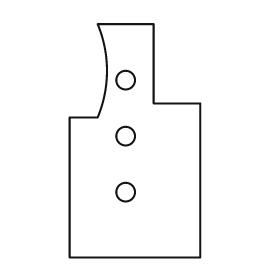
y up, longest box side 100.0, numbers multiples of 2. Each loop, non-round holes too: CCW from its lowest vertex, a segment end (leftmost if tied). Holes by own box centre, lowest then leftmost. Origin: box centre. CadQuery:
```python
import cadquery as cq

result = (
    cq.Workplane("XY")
    .moveTo(-28.0, -50.0)
    .lineTo(28.0, -50.0)
    .lineTo(28.0, 16.0)
    .lineTo(8.0, 16.0)
    .lineTo(8.0, 50.0)
    .lineTo(-16.0, 50.0)
    .threePointArc((-12.0, 30.0), (-16.0, 10.0))
    .lineTo(-28.0, 10.0)
    .close()
    .moveTo(-4.0, -22.0)
    .circle(4.0)
    .moveTo(-4.0, 2.0)
    .circle(4.0)
    .moveTo(-4.0, 26.0)
    .circle(4.0)
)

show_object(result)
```